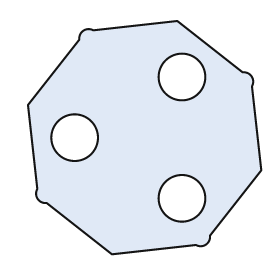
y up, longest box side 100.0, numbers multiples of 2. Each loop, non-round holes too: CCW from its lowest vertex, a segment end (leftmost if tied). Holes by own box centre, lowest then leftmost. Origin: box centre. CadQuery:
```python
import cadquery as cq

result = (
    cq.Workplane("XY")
    .moveTo(-14.0, -50.0)
    .lineTo(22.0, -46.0)
    .threePointArc((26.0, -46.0), (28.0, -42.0))
    .lineTo(50.0, -14.0)
    .lineTo(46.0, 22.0)
    .threePointArc((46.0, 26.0), (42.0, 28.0))
    .lineTo(14.0, 50.0)
    .lineTo(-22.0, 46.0)
    .threePointArc((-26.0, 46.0), (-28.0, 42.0))
    .lineTo(-50.0, 14.0)
    .lineTo(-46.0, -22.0)
    .threePointArc((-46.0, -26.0), (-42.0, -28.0))
    .close()
    .moveTo(16.0, -26.0)
    .circle(10.0)
    .moveTo(-30.0, 0.0)
    .circle(10.0)
    .moveTo(16.0, 26.0)
    .circle(10.0)
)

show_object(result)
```